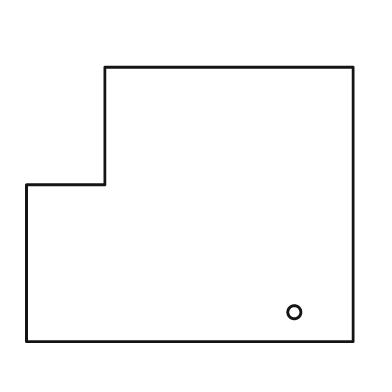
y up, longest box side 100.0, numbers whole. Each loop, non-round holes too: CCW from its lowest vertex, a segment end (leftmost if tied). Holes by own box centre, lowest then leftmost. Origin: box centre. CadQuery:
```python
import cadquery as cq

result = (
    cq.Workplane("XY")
    .moveTo(-50.0, -42.0)
    .lineTo(50.0, -42.0)
    .lineTo(50.0, 42.0)
    .lineTo(-26.0, 42.0)
    .lineTo(-26.0, 6.0)
    .lineTo(-50.0, 6.0)
    .close()
    .moveTo(32.0, -33.0)
    .circle(2.0)
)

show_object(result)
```